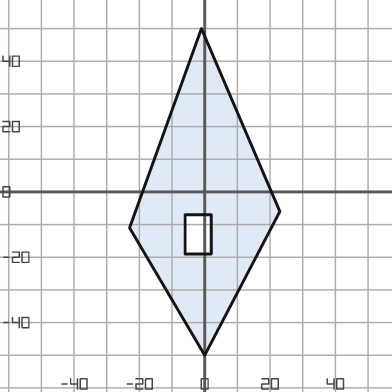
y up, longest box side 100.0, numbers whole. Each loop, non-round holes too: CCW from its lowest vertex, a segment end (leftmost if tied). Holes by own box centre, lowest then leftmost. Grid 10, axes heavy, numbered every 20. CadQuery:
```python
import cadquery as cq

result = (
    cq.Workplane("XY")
    .moveTo(0.0, -50.0)
    .lineTo(23.0, -6.0)
    .lineTo(-1.0, 50.0)
    .lineTo(-23.0, -11.0)
    .close()
    .moveTo(-6.0, -19.0)
    .lineTo(2.0, -19.0)
    .lineTo(2.0, -7.0)
    .lineTo(-6.0, -7.0)
    .close()
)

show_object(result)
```